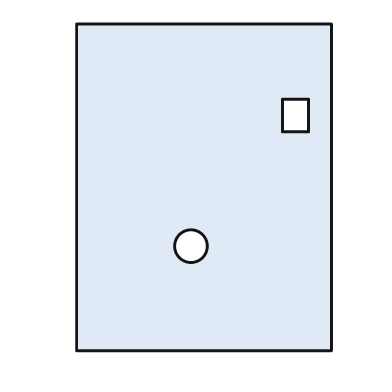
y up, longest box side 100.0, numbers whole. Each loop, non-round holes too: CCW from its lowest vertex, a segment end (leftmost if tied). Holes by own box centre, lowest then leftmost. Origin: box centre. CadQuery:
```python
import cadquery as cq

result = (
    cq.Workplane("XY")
    .moveTo(-39.0, -50.0)
    .lineTo(39.0, -50.0)
    .lineTo(39.0, 50.0)
    .lineTo(-39.0, 50.0)
    .close()
    .moveTo(-4.0, -18.0)
    .circle(5.0)
    .moveTo(24.0, 17.0)
    .lineTo(32.0, 17.0)
    .lineTo(32.0, 27.0)
    .lineTo(24.0, 27.0)
    .close()
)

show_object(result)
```